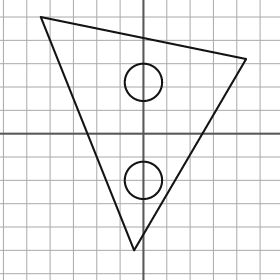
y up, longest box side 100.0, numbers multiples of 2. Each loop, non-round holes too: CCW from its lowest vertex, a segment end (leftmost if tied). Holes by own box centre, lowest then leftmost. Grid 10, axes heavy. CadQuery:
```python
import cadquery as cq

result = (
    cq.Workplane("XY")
    .moveTo(-4.0, -50.0)
    .lineTo(44.0, 32.0)
    .lineTo(-44.0, 50.0)
    .close()
    .moveTo(0.0, -20.0)
    .circle(8.0)
    .moveTo(0.0, 22.0)
    .circle(8.0)
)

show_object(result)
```